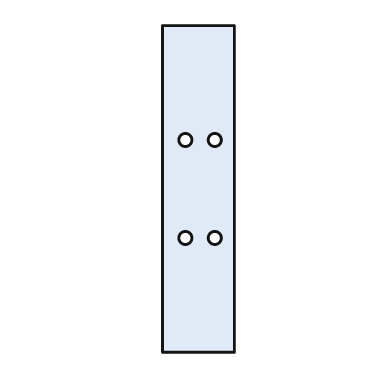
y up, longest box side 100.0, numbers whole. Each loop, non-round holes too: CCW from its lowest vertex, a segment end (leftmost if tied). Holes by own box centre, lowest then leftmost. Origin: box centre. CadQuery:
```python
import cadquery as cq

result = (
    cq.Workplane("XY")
    .moveTo(-11.0, -50.0)
    .lineTo(11.0, -50.0)
    .lineTo(11.0, 50.0)
    .lineTo(-11.0, 50.0)
    .close()
    .moveTo(-4.0, -15.0)
    .circle(2.0)
    .moveTo(5.0, -15.0)
    .circle(2.0)
    .moveTo(-4.0, 15.0)
    .circle(2.0)
    .moveTo(5.0, 15.0)
    .circle(2.0)
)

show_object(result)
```